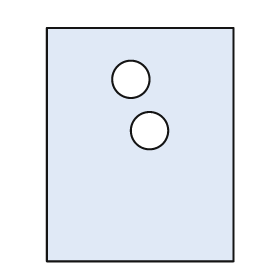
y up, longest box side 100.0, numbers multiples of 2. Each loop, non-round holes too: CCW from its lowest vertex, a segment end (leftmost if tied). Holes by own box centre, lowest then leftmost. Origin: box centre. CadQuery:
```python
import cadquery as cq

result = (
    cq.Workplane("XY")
    .moveTo(-40.0, -50.0)
    .lineTo(40.0, -50.0)
    .lineTo(40.0, 50.0)
    .lineTo(-40.0, 50.0)
    .close()
    .moveTo(4.0, 6.0)
    .circle(8.0)
    .moveTo(-4.0, 28.0)
    .circle(8.0)
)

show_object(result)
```